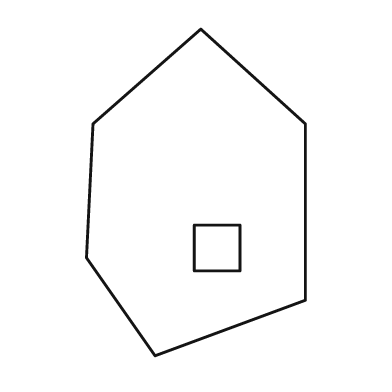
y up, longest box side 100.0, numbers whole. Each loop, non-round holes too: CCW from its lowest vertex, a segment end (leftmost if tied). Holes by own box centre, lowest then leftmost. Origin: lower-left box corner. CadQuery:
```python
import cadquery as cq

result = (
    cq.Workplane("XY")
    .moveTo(21.0, 0.0)
    .lineTo(67.0, 17.0)
    .lineTo(67.0, 71.0)
    .lineTo(35.0, 100.0)
    .lineTo(2.0, 71.0)
    .lineTo(0.0, 30.0)
    .close()
    .moveTo(33.0, 26.0)
    .lineTo(47.0, 26.0)
    .lineTo(47.0, 40.0)
    .lineTo(33.0, 40.0)
    .close()
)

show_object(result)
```